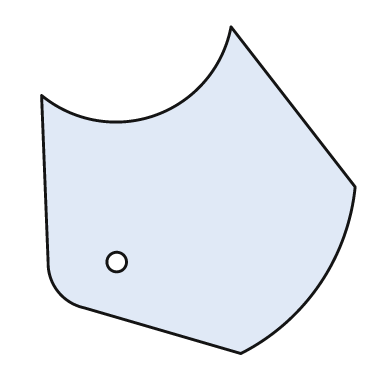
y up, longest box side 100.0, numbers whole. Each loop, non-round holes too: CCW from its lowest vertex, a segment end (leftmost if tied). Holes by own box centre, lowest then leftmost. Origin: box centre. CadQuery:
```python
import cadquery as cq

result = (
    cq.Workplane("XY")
    .moveTo(13.0, -50.0)
    .threePointArc((37.0, -29.0), (48.0, 1.0))
    .lineTo(10.0, 50.0)
    .threePointArc((-13.0, 23.0), (-48.0, 29.0))
    .lineTo(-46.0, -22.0)
    .threePointArc((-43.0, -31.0), (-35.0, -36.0))
    .close()
    .moveTo(-25.0, -22.0)
    .circle(3.0)
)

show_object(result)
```